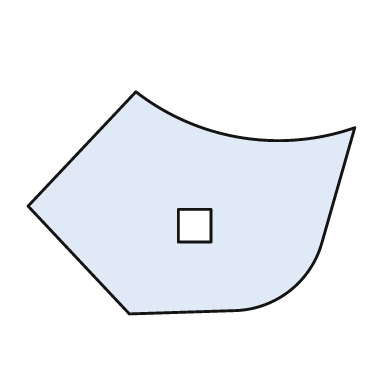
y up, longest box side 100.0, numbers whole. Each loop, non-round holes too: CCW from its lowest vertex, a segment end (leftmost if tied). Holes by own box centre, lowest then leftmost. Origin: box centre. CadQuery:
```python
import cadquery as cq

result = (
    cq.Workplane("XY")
    .moveTo(-19.0, -34.0)
    .lineTo(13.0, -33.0)
    .threePointArc((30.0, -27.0), (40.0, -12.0))
    .lineTo(50.0, 23.0)
    .threePointArc((15.0, 20.0), (-17.0, 34.0))
    .lineTo(-50.0, -1.0)
    .close()
    .moveTo(-4.0, -12.0)
    .lineTo(6.0, -12.0)
    .lineTo(6.0, -2.0)
    .lineTo(-4.0, -2.0)
    .close()
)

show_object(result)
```